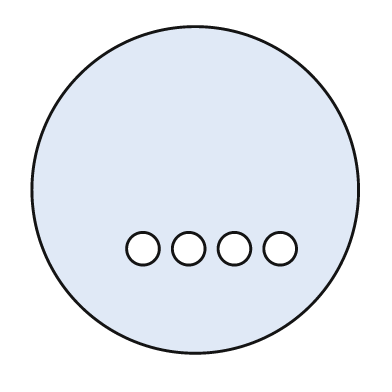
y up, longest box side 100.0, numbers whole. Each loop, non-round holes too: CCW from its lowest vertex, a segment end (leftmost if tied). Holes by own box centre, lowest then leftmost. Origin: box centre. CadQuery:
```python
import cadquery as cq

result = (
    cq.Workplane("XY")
    .moveTo(0.0, 0.0)
    .circle(50.0)
    .moveTo(-16.0, -18.0)
    .circle(5.0)
    .moveTo(-2.0, -18.0)
    .circle(5.0)
    .moveTo(12.0, -18.0)
    .circle(5.0)
    .moveTo(26.0, -18.0)
    .circle(5.0)
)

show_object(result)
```